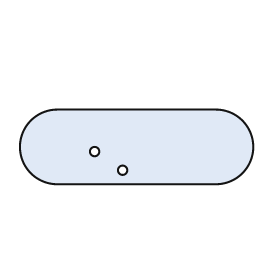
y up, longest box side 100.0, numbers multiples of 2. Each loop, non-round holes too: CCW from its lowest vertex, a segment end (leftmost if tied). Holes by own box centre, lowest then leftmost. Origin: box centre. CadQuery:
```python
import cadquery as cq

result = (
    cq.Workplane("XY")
    .moveTo(-34.0, -16.0)
    .lineTo(34.0, -16.0)
    .threePointArc((50.0, 0.0), (34.0, 16.0))
    .lineTo(-34.0, 16.0)
    .threePointArc((-50.0, 0.0), (-34.0, -16.0))
    .close()
    .moveTo(-6.0, -10.0)
    .circle(2.0)
    .moveTo(-18.0, -2.0)
    .circle(2.0)
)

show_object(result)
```